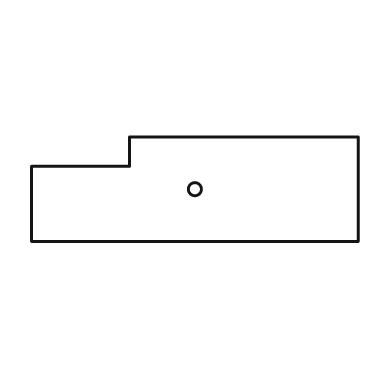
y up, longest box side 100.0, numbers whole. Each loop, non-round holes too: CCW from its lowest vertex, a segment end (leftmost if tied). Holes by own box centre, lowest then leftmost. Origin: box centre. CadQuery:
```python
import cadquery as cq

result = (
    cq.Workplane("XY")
    .moveTo(-50.0, -16.0)
    .lineTo(50.0, -16.0)
    .lineTo(50.0, 16.0)
    .lineTo(-20.0, 16.0)
    .lineTo(-20.0, 7.0)
    .lineTo(-50.0, 7.0)
    .close()
    .moveTo(0.0, 0.0)
    .circle(2.0)
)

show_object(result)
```